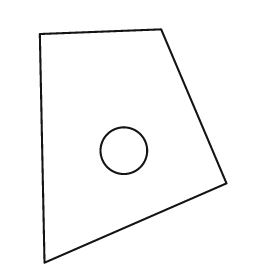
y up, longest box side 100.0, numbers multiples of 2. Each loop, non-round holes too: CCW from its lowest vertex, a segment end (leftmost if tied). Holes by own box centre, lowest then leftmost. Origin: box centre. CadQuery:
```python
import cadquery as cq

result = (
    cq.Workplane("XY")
    .moveTo(-38.0, -50.0)
    .lineTo(40.0, -16.0)
    .lineTo(12.0, 50.0)
    .lineTo(-40.0, 48.0)
    .close()
    .moveTo(-4.0, -2.0)
    .circle(10.0)
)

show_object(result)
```